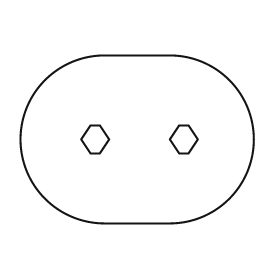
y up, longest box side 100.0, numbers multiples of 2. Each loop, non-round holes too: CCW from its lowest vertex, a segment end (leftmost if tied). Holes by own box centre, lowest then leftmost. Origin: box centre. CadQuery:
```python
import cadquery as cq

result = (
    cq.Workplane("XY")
    .moveTo(-14.0, -36.0)
    .lineTo(14.0, -36.0)
    .threePointArc((50.0, 0.0), (14.0, 36.0))
    .lineTo(-14.0, 36.0)
    .threePointArc((-50.0, 0.0), (-14.0, -36.0))
    .close()
    .moveTo(-20.0, -6.0)
    .lineTo(-16.0, -6.0)
    .lineTo(-12.0, 0.0)
    .lineTo(-16.0, 6.0)
    .lineTo(-20.0, 6.0)
    .lineTo(-24.0, 0.0)
    .close()
    .moveTo(18.0, -6.0)
    .lineTo(22.0, -6.0)
    .lineTo(26.0, 0.0)
    .lineTo(22.0, 6.0)
    .lineTo(18.0, 6.0)
    .lineTo(14.0, 0.0)
    .close()
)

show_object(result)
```